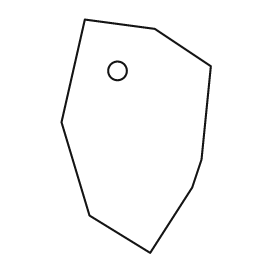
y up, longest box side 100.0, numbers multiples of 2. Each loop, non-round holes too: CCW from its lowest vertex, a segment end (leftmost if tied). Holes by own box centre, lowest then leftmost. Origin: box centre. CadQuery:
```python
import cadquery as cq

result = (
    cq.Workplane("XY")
    .moveTo(6.0, -50.0)
    .lineTo(24.0, -22.0)
    .lineTo(28.0, -10.0)
    .lineTo(32.0, 30.0)
    .lineTo(8.0, 46.0)
    .lineTo(-22.0, 50.0)
    .lineTo(-32.0, 6.0)
    .lineTo(-20.0, -34.0)
    .close()
    .moveTo(-8.0, 28.0)
    .circle(4.0)
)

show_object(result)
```